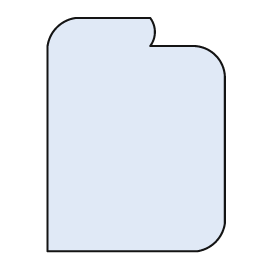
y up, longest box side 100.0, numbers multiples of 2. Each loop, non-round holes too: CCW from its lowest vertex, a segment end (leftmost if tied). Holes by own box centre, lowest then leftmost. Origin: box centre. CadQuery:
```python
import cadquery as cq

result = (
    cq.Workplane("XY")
    .moveTo(-38.0, -50.0)
    .lineTo(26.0, -50.0)
    .threePointArc((34.0, -46.0), (38.0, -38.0))
    .lineTo(38.0, 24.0)
    .threePointArc((34.0, 34.0), (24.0, 38.0))
    .lineTo(6.0, 38.0)
    .threePointArc((8.0, 44.0), (6.0, 50.0))
    .lineTo(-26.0, 50.0)
    .threePointArc((-34.0, 46.0), (-38.0, 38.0))
    .close()
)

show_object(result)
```